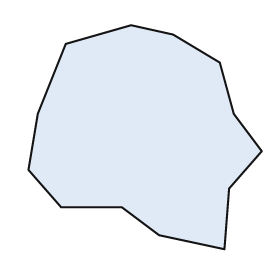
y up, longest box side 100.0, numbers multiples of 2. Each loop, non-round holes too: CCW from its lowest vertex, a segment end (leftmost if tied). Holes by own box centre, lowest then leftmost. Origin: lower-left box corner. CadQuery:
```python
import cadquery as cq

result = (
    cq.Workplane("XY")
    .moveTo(84.0, 0.0)
    .lineTo(86.0, 26.0)
    .lineTo(100.0, 42.0)
    .lineTo(88.0, 58.0)
    .lineTo(82.0, 80.0)
    .lineTo(62.0, 92.0)
    .lineTo(44.0, 96.0)
    .lineTo(16.0, 88.0)
    .lineTo(4.0, 58.0)
    .lineTo(0.0, 34.0)
    .lineTo(14.0, 18.0)
    .lineTo(40.0, 18.0)
    .lineTo(56.0, 6.0)
    .close()
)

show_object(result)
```